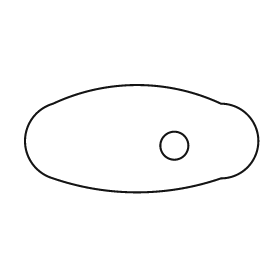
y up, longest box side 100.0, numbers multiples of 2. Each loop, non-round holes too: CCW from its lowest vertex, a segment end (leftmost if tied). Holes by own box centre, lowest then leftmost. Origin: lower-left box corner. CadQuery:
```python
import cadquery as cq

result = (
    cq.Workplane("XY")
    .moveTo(12.0, 6.0)
    .threePointArc((48.0, 0.0), (84.0, 6.0))
    .threePointArc((100.0, 22.0), (84.0, 38.0))
    .threePointArc((48.0, 46.0), (12.0, 38.0))
    .threePointArc((0.0, 22.0), (12.0, 6.0))
    .close()
    .moveTo(64.0, 20.0)
    .circle(6.0)
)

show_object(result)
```